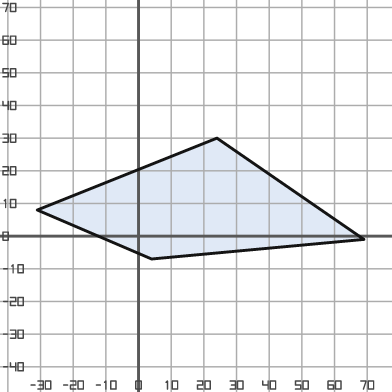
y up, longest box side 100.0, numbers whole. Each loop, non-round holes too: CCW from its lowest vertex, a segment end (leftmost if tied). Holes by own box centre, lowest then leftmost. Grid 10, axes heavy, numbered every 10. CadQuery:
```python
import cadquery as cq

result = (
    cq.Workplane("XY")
    .moveTo(4.0, -7.0)
    .lineTo(69.0, -1.0)
    .lineTo(24.0, 30.0)
    .lineTo(-31.0, 8.0)
    .close()
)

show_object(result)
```